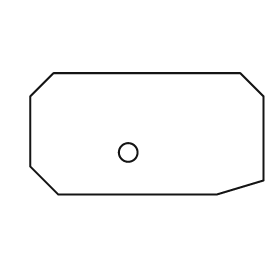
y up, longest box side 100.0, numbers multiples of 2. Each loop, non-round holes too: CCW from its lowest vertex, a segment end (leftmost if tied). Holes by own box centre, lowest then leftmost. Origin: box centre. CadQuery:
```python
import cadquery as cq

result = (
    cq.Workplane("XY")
    .moveTo(-38.0, -26.0)
    .lineTo(30.0, -26.0)
    .lineTo(50.0, -20.0)
    .lineTo(50.0, 16.0)
    .lineTo(40.0, 26.0)
    .lineTo(-40.0, 26.0)
    .lineTo(-50.0, 16.0)
    .lineTo(-50.0, -14.0)
    .close()
    .moveTo(-8.0, -8.0)
    .circle(4.0)
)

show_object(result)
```